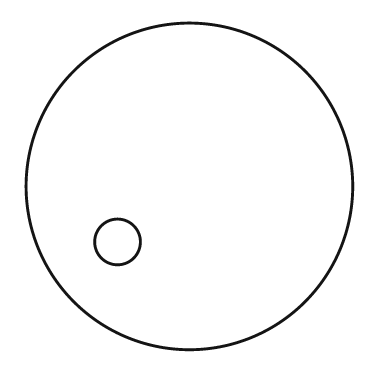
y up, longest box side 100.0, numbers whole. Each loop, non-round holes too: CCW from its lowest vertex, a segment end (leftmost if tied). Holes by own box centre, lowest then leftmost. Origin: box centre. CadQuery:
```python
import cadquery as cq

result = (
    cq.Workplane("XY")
    .moveTo(0.0, 0.0)
    .circle(50.0)
    .moveTo(-22.0, -17.0)
    .circle(7.0)
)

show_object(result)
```